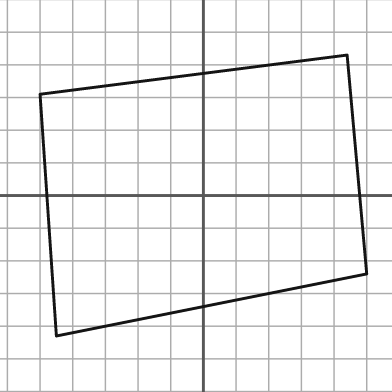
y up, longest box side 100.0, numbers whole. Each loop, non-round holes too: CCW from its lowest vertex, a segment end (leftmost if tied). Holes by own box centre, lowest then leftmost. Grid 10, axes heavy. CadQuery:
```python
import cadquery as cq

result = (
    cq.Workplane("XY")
    .moveTo(-45.0, -43.0)
    .lineTo(50.0, -24.0)
    .lineTo(44.0, 43.0)
    .lineTo(-50.0, 31.0)
    .close()
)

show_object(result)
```